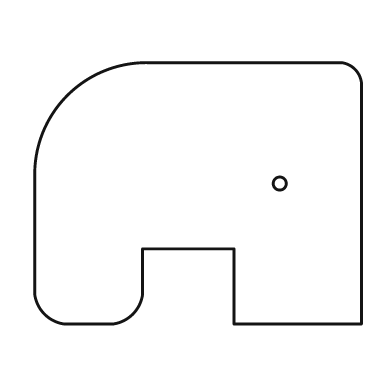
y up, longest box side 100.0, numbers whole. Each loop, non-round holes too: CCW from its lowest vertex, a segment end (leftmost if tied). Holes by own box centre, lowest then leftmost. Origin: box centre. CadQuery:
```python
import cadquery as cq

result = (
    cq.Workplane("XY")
    .moveTo(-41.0, -40.0)
    .lineTo(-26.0, -40.0)
    .threePointArc((-20.0, -37.0), (-17.0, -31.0))
    .lineTo(-17.0, -17.0)
    .lineTo(11.0, -17.0)
    .lineTo(11.0, -40.0)
    .lineTo(50.0, -40.0)
    .lineTo(50.0, 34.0)
    .threePointArc((48.0, 38.0), (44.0, 40.0))
    .lineTo(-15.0, 40.0)
    .threePointArc((-40.0, 30.0), (-50.0, 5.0))
    .lineTo(-50.0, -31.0)
    .threePointArc((-47.0, -37.0), (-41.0, -40.0))
    .close()
    .moveTo(25.0, 3.0)
    .circle(2.0)
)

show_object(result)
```